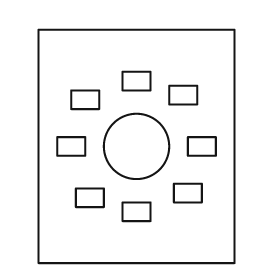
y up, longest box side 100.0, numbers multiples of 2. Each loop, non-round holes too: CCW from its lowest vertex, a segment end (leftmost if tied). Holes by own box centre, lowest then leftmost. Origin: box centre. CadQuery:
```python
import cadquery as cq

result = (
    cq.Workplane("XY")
    .moveTo(-42.0, -50.0)
    .lineTo(42.0, -50.0)
    .lineTo(42.0, 50.0)
    .lineTo(-42.0, 50.0)
    .close()
    .moveTo(-6.0, -32.0)
    .lineTo(6.0, -32.0)
    .lineTo(6.0, -24.0)
    .lineTo(-6.0, -24.0)
    .close()
    .moveTo(-26.0, -26.0)
    .lineTo(-14.0, -26.0)
    .lineTo(-14.0, -18.0)
    .lineTo(-26.0, -18.0)
    .close()
    .moveTo(16.0, -24.0)
    .lineTo(28.0, -24.0)
    .lineTo(28.0, -16.0)
    .lineTo(16.0, -16.0)
    .close()
    .moveTo(-34.0, -4.0)
    .lineTo(-22.0, -4.0)
    .lineTo(-22.0, 4.0)
    .lineTo(-34.0, 4.0)
    .close()
    .moveTo(0.0, 0.0)
    .circle(14.0)
    .moveTo(22.0, -4.0)
    .lineTo(34.0, -4.0)
    .lineTo(34.0, 4.0)
    .lineTo(22.0, 4.0)
    .close()
    .moveTo(-28.0, 16.0)
    .lineTo(-16.0, 16.0)
    .lineTo(-16.0, 24.0)
    .lineTo(-28.0, 24.0)
    .close()
    .moveTo(14.0, 18.0)
    .lineTo(26.0, 18.0)
    .lineTo(26.0, 26.0)
    .lineTo(14.0, 26.0)
    .close()
    .moveTo(-6.0, 24.0)
    .lineTo(6.0, 24.0)
    .lineTo(6.0, 32.0)
    .lineTo(-6.0, 32.0)
    .close()
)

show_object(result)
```